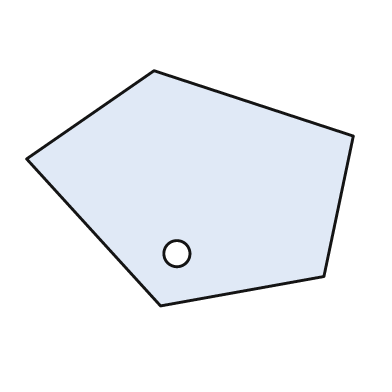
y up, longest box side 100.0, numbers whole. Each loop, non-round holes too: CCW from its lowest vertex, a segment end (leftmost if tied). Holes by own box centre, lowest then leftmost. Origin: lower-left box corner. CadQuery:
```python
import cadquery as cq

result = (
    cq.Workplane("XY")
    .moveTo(41.0, 0.0)
    .lineTo(91.0, 9.0)
    .lineTo(100.0, 52.0)
    .lineTo(39.0, 72.0)
    .lineTo(0.0, 45.0)
    .close()
    .moveTo(46.0, 16.0)
    .circle(4.0)
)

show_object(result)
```